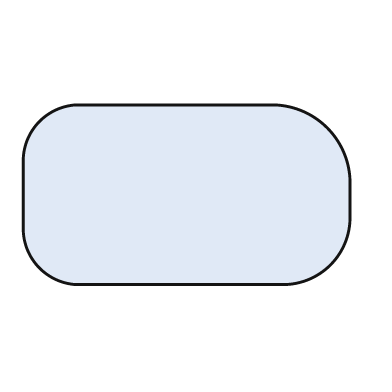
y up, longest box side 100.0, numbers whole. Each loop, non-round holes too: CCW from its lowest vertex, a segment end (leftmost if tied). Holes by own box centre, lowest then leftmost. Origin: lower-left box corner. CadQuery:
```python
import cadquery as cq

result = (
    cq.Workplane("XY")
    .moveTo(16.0, 0.0)
    .lineTo(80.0, 0.0)
    .threePointArc((94.0, 6.0), (100.0, 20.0))
    .lineTo(100.0, 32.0)
    .threePointArc((93.0, 48.0), (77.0, 55.0))
    .lineTo(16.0, 55.0)
    .threePointArc((5.0, 50.0), (0.0, 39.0))
    .lineTo(0.0, 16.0)
    .threePointArc((5.0, 5.0), (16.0, 0.0))
    .close()
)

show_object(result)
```